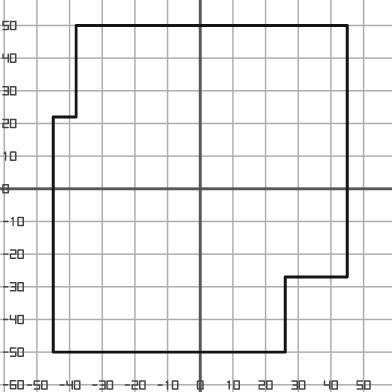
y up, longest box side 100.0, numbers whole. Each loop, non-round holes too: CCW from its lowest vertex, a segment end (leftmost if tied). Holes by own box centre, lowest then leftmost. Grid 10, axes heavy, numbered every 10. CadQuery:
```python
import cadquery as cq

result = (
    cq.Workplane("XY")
    .moveTo(-45.0, -50.0)
    .lineTo(26.0, -50.0)
    .lineTo(26.0, -27.0)
    .lineTo(45.0, -27.0)
    .lineTo(45.0, 50.0)
    .lineTo(-38.0, 50.0)
    .lineTo(-38.0, 22.0)
    .lineTo(-45.0, 22.0)
    .close()
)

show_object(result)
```